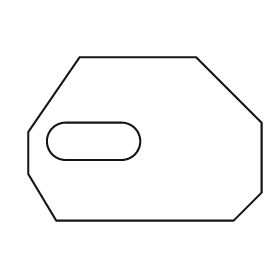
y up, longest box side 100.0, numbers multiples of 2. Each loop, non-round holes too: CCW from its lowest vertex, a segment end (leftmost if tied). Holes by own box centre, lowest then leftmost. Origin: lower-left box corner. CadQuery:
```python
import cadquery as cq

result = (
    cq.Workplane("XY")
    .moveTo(12.0, 0.0)
    .lineTo(88.0, 0.0)
    .lineTo(100.0, 12.0)
    .lineTo(100.0, 42.0)
    .lineTo(72.0, 70.0)
    .lineTo(22.0, 70.0)
    .lineTo(0.0, 38.0)
    .lineTo(0.0, 20.0)
    .close()
    .moveTo(16.0, 26.0)
    .lineTo(40.0, 26.0)
    .threePointArc((48.0, 34.0), (40.0, 42.0))
    .lineTo(16.0, 42.0)
    .threePointArc((8.0, 34.0), (16.0, 26.0))
    .close()
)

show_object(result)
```